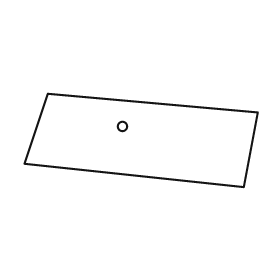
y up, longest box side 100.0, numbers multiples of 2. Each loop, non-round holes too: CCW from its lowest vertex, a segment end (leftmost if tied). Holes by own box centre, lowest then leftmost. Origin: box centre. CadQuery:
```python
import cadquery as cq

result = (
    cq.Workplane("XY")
    .moveTo(44.0, -20.0)
    .lineTo(50.0, 12.0)
    .lineTo(-40.0, 20.0)
    .lineTo(-50.0, -10.0)
    .close()
    .moveTo(-8.0, 6.0)
    .circle(2.0)
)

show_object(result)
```